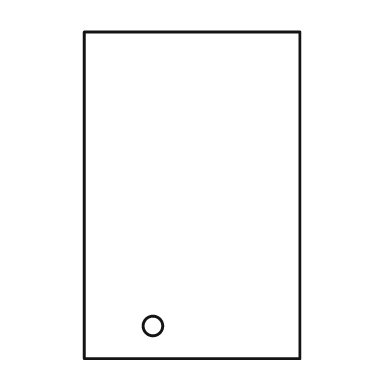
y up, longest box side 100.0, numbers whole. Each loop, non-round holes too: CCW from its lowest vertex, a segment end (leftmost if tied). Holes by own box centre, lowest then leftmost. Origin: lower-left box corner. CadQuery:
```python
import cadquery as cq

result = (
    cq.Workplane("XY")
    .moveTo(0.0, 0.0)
    .lineTo(66.0, 0.0)
    .lineTo(66.0, 100.0)
    .lineTo(0.0, 100.0)
    .close()
    .moveTo(21.0, 10.0)
    .circle(3.0)
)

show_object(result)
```